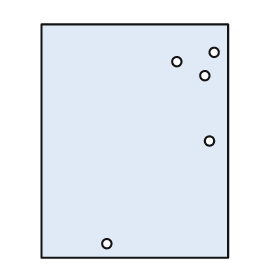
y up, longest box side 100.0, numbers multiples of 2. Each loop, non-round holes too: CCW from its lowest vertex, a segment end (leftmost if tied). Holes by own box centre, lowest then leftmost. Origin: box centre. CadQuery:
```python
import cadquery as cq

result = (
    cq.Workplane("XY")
    .moveTo(-40.0, -50.0)
    .lineTo(40.0, -50.0)
    .lineTo(40.0, 50.0)
    .lineTo(-40.0, 50.0)
    .close()
    .moveTo(-12.0, -44.0)
    .circle(2.0)
    .moveTo(32.0, 0.0)
    .circle(2.0)
    .moveTo(30.0, 28.0)
    .circle(2.0)
    .moveTo(18.0, 34.0)
    .circle(2.0)
    .moveTo(34.0, 38.0)
    .circle(2.0)
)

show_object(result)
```